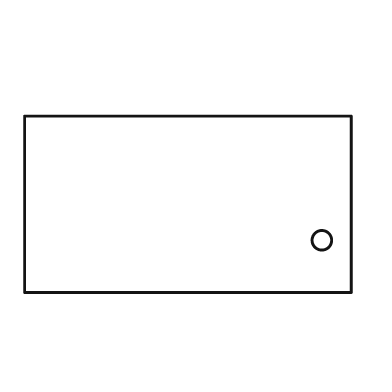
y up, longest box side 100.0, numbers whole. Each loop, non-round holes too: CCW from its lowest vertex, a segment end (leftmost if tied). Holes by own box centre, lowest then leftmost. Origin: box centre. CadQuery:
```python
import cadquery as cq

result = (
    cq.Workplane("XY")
    .moveTo(-50.0, -27.0)
    .lineTo(50.0, -27.0)
    .lineTo(50.0, 27.0)
    .lineTo(-50.0, 27.0)
    .close()
    .moveTo(41.0, -11.0)
    .circle(3.0)
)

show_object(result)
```